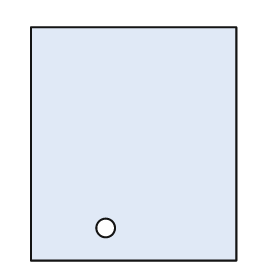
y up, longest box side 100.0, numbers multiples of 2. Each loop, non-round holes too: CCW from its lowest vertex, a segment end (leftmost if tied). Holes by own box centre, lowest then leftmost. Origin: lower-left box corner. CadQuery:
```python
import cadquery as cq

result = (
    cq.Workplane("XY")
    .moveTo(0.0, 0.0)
    .lineTo(88.0, 0.0)
    .lineTo(88.0, 100.0)
    .lineTo(0.0, 100.0)
    .close()
    .moveTo(32.0, 14.0)
    .circle(4.0)
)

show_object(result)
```